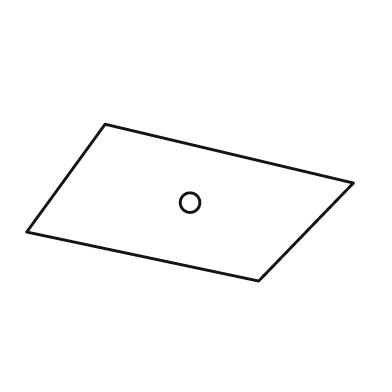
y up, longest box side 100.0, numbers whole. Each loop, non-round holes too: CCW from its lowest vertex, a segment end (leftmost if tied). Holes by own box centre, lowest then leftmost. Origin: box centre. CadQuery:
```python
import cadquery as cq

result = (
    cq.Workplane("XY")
    .moveTo(21.0, -24.0)
    .lineTo(50.0, 6.0)
    .lineTo(-26.0, 24.0)
    .lineTo(-50.0, -9.0)
    .close()
    .moveTo(0.0, 0.0)
    .circle(3.0)
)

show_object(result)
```